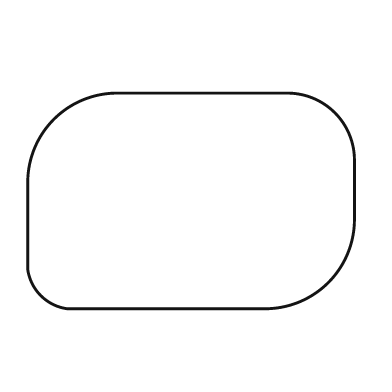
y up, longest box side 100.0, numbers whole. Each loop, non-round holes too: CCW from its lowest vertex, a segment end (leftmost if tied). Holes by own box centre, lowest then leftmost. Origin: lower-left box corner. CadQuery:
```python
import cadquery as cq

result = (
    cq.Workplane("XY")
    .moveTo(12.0, 0.0)
    .lineTo(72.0, 0.0)
    .threePointArc((92.0, 8.0), (100.0, 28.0))
    .lineTo(100.0, 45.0)
    .threePointArc((94.0, 60.0), (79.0, 66.0))
    .lineTo(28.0, 66.0)
    .threePointArc((8.0, 58.0), (0.0, 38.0))
    .lineTo(0.0, 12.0)
    .threePointArc((4.0, 4.0), (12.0, 0.0))
    .close()
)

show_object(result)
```